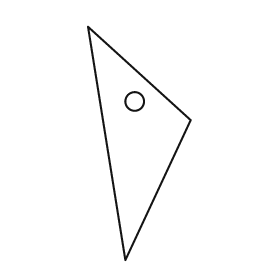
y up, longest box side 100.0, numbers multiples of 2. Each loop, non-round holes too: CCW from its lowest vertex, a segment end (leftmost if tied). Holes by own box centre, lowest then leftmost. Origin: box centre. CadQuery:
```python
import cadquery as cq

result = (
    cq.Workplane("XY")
    .moveTo(-6.0, -50.0)
    .lineTo(22.0, 10.0)
    .lineTo(-22.0, 50.0)
    .close()
    .moveTo(-2.0, 18.0)
    .circle(4.0)
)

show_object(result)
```